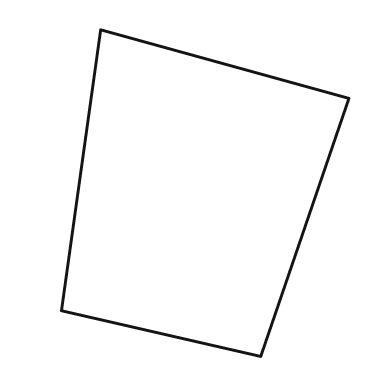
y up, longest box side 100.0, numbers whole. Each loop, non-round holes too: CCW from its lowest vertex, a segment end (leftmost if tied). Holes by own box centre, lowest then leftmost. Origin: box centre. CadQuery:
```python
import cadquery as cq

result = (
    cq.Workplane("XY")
    .moveTo(17.0, -50.0)
    .lineTo(44.0, 29.0)
    .lineTo(-32.0, 50.0)
    .lineTo(-44.0, -36.0)
    .close()
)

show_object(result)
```